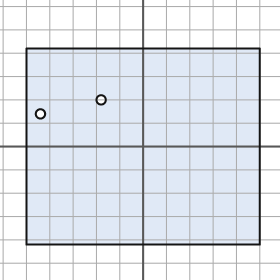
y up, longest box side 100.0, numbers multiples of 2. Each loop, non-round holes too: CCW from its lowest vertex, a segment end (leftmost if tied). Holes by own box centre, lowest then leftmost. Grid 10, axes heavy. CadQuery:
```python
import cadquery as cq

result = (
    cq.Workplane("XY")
    .moveTo(-50.0, -42.0)
    .lineTo(50.0, -42.0)
    .lineTo(50.0, 42.0)
    .lineTo(-50.0, 42.0)
    .close()
    .moveTo(-44.0, 14.0)
    .circle(2.0)
    .moveTo(-18.0, 20.0)
    .circle(2.0)
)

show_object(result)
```